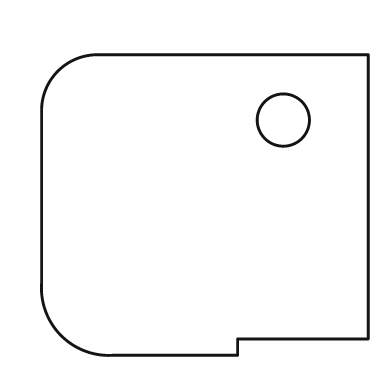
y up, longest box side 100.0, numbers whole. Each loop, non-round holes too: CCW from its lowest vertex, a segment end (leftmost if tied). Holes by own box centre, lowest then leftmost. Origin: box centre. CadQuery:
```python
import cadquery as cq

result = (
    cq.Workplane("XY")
    .moveTo(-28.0, -46.0)
    .lineTo(10.0, -46.0)
    .lineTo(10.0, -41.0)
    .lineTo(50.0, -41.0)
    .lineTo(50.0, 46.0)
    .lineTo(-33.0, 46.0)
    .threePointArc((-45.0, 41.0), (-50.0, 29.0))
    .lineTo(-50.0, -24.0)
    .threePointArc((-44.0, -40.0), (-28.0, -46.0))
    .close()
    .moveTo(24.0, 26.0)
    .circle(8.0)
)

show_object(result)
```